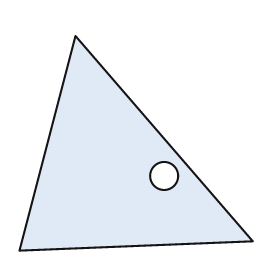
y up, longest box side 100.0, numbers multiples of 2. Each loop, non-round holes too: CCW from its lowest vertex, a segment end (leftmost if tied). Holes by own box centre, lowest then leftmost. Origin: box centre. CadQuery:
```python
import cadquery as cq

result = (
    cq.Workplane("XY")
    .moveTo(-50.0, -46.0)
    .lineTo(50.0, -42.0)
    .lineTo(-26.0, 46.0)
    .close()
    .moveTo(12.0, -14.0)
    .circle(6.0)
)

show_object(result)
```